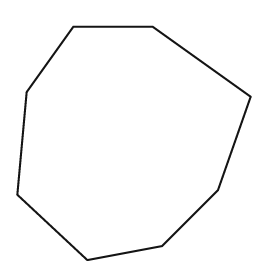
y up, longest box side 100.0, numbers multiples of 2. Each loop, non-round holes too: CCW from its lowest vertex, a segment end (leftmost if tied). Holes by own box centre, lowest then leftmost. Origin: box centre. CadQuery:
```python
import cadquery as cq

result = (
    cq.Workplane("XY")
    .moveTo(-20.0, -50.0)
    .lineTo(12.0, -44.0)
    .lineTo(36.0, -20.0)
    .lineTo(50.0, 20.0)
    .lineTo(8.0, 50.0)
    .lineTo(-26.0, 50.0)
    .lineTo(-46.0, 22.0)
    .lineTo(-50.0, -22.0)
    .close()
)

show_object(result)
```